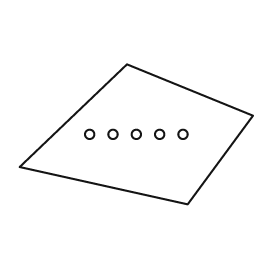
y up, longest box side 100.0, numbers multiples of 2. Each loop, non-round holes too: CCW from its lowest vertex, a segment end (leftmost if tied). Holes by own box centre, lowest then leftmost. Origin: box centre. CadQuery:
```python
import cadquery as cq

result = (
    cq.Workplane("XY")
    .moveTo(22.0, -30.0)
    .lineTo(50.0, 8.0)
    .lineTo(-4.0, 30.0)
    .lineTo(-50.0, -14.0)
    .close()
    .moveTo(-20.0, 0.0)
    .circle(2.0)
    .moveTo(-10.0, 0.0)
    .circle(2.0)
    .moveTo(0.0, 0.0)
    .circle(2.0)
    .moveTo(10.0, 0.0)
    .circle(2.0)
    .moveTo(20.0, 0.0)
    .circle(2.0)
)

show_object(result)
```